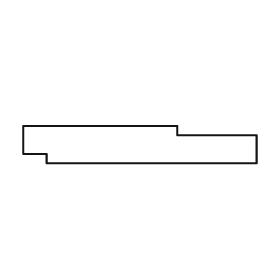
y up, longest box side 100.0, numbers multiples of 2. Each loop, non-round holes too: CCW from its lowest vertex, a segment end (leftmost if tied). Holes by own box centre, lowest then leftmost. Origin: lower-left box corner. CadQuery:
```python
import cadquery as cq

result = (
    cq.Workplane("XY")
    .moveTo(10.0, 0.0)
    .lineTo(100.0, 0.0)
    .lineTo(100.0, 12.0)
    .lineTo(66.0, 12.0)
    .lineTo(66.0, 16.0)
    .lineTo(0.0, 16.0)
    .lineTo(0.0, 4.0)
    .lineTo(10.0, 4.0)
    .close()
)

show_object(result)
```